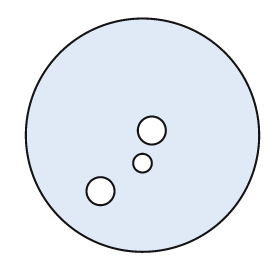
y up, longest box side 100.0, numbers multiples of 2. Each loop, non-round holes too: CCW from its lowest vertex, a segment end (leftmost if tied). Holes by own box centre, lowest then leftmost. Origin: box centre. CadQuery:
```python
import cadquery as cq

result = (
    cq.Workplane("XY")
    .moveTo(0.0, 0.0)
    .circle(50.0)
    .moveTo(-18.0, -24.0)
    .circle(6.0)
    .moveTo(0.0, -12.0)
    .circle(4.0)
    .moveTo(4.0, 2.0)
    .circle(6.0)
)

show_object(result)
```